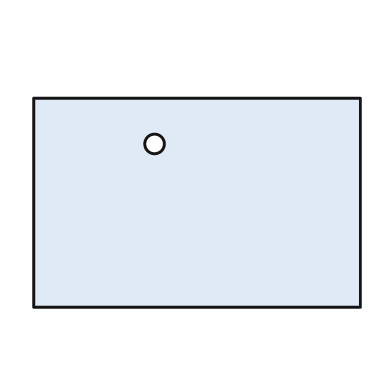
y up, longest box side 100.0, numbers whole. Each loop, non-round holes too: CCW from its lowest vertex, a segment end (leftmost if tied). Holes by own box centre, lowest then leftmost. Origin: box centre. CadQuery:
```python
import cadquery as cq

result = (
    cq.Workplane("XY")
    .moveTo(-50.0, -32.0)
    .lineTo(50.0, -32.0)
    .lineTo(50.0, 32.0)
    .lineTo(-50.0, 32.0)
    .close()
    .moveTo(-13.0, 18.0)
    .circle(3.0)
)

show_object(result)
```